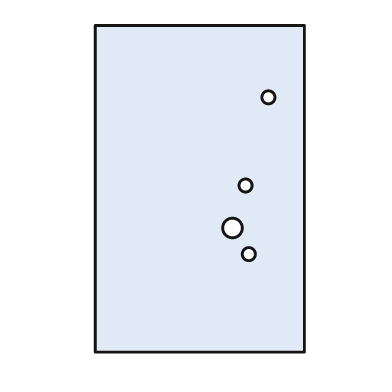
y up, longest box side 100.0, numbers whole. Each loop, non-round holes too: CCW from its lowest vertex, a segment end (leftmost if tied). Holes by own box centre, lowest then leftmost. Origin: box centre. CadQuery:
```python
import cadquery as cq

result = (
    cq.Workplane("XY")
    .moveTo(-32.0, -50.0)
    .lineTo(32.0, -50.0)
    .lineTo(32.0, 50.0)
    .lineTo(-32.0, 50.0)
    .close()
    .moveTo(15.0, -20.0)
    .circle(2.0)
    .moveTo(10.0, -12.0)
    .circle(3.0)
    .moveTo(14.0, 1.0)
    .circle(2.0)
    .moveTo(21.0, 28.0)
    .circle(2.0)
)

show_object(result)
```